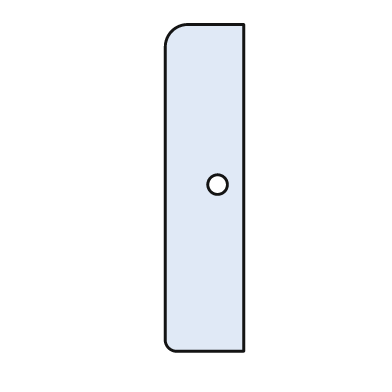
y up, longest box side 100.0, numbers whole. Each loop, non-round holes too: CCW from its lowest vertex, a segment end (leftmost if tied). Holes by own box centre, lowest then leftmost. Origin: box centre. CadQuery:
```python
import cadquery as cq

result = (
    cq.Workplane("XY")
    .moveTo(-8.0, -50.0)
    .lineTo(12.0, -50.0)
    .lineTo(12.0, 50.0)
    .lineTo(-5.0, 50.0)
    .threePointArc((-10.0, 48.0), (-12.0, 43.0))
    .lineTo(-12.0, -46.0)
    .threePointArc((-11.0, -49.0), (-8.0, -50.0))
    .close()
    .moveTo(4.0, 1.0)
    .circle(3.0)
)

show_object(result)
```